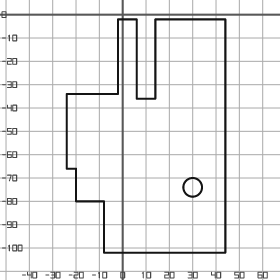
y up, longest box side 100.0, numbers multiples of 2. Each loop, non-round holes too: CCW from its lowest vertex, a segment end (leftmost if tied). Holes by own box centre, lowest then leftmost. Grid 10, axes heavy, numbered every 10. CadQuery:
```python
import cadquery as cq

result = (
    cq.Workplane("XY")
    .moveTo(-8.0, -102.0)
    .lineTo(44.0, -102.0)
    .lineTo(44.0, -2.0)
    .lineTo(14.0, -2.0)
    .lineTo(14.0, -36.0)
    .lineTo(6.0, -36.0)
    .lineTo(6.0, -2.0)
    .lineTo(-2.0, -2.0)
    .lineTo(-2.0, -34.0)
    .lineTo(-24.0, -34.0)
    .lineTo(-24.0, -66.0)
    .lineTo(-20.0, -66.0)
    .lineTo(-20.0, -80.0)
    .lineTo(-8.0, -80.0)
    .close()
    .moveTo(30.0, -74.0)
    .circle(4.0)
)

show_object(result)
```